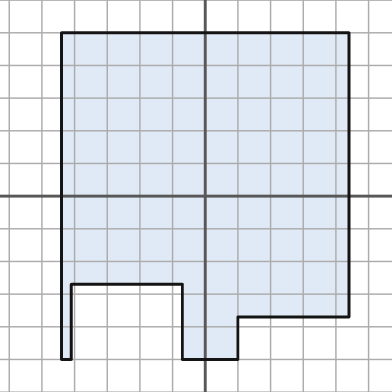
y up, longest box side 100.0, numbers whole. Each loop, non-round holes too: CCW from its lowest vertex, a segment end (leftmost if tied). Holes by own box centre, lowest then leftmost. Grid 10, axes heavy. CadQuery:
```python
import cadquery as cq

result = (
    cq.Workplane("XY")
    .moveTo(-44.0, -50.0)
    .lineTo(-41.0, -50.0)
    .lineTo(-41.0, -27.0)
    .lineTo(-7.0, -27.0)
    .lineTo(-7.0, -50.0)
    .lineTo(10.0, -50.0)
    .lineTo(10.0, -37.0)
    .lineTo(44.0, -37.0)
    .lineTo(44.0, 50.0)
    .lineTo(-44.0, 50.0)
    .close()
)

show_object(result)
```